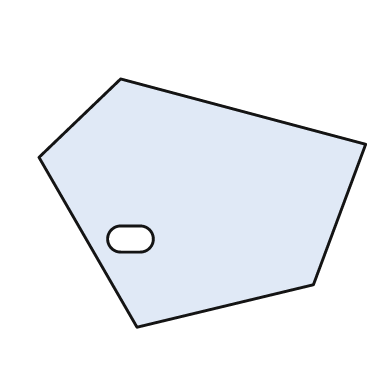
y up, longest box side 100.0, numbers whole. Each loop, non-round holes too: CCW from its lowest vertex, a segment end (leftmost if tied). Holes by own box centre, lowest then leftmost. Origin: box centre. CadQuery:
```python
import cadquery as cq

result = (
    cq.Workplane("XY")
    .moveTo(-20.0, -38.0)
    .lineTo(34.0, -25.0)
    .lineTo(50.0, 18.0)
    .lineTo(-25.0, 38.0)
    .lineTo(-50.0, 14.0)
    .close()
    .moveTo(-25.0, -15.0)
    .lineTo(-19.0, -15.0)
    .threePointArc((-15.0, -11.0), (-19.0, -7.0))
    .lineTo(-25.0, -7.0)
    .threePointArc((-29.0, -11.0), (-25.0, -15.0))
    .close()
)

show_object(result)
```